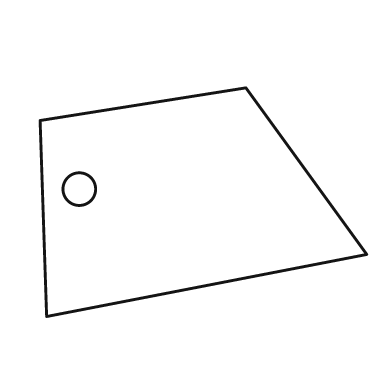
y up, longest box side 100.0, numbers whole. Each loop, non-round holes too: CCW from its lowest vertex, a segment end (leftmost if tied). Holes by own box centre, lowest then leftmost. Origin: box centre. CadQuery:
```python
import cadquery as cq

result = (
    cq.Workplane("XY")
    .moveTo(-48.0, -35.0)
    .lineTo(50.0, -16.0)
    .lineTo(13.0, 35.0)
    .lineTo(-50.0, 25.0)
    .close()
    .moveTo(-38.0, 4.0)
    .circle(5.0)
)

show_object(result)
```